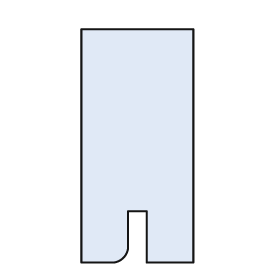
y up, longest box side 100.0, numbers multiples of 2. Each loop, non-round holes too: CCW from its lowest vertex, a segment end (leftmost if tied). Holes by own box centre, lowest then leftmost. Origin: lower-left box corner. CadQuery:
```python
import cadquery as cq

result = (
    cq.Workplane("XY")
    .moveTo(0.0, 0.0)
    .lineTo(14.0, 0.0)
    .threePointArc((18.0, 2.0), (20.0, 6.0))
    .lineTo(20.0, 22.0)
    .lineTo(28.0, 22.0)
    .lineTo(28.0, 0.0)
    .lineTo(48.0, 0.0)
    .lineTo(48.0, 100.0)
    .lineTo(0.0, 100.0)
    .close()
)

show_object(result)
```